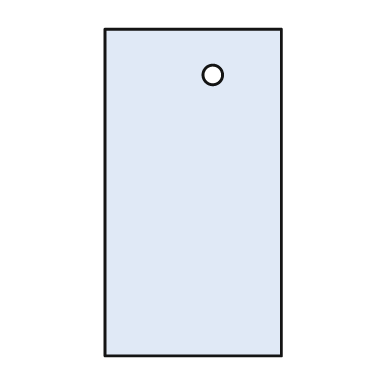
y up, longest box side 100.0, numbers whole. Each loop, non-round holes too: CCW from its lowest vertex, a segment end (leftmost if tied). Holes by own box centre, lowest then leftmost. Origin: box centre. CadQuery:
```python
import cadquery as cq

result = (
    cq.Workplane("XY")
    .moveTo(-27.0, -50.0)
    .lineTo(27.0, -50.0)
    .lineTo(27.0, 50.0)
    .lineTo(-27.0, 50.0)
    .close()
    .moveTo(6.0, 36.0)
    .circle(3.0)
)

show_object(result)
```